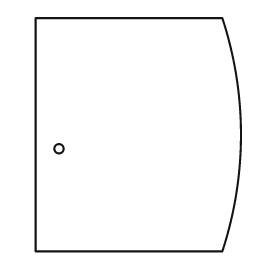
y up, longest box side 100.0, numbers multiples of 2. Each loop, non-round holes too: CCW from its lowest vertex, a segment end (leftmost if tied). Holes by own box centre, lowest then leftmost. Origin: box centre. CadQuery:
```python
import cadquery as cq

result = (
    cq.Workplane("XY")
    .moveTo(-44.0, -50.0)
    .lineTo(36.0, -50.0)
    .threePointArc((44.0, 0.0), (36.0, 50.0))
    .lineTo(-44.0, 50.0)
    .close()
    .moveTo(-34.0, -6.0)
    .circle(2.0)
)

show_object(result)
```